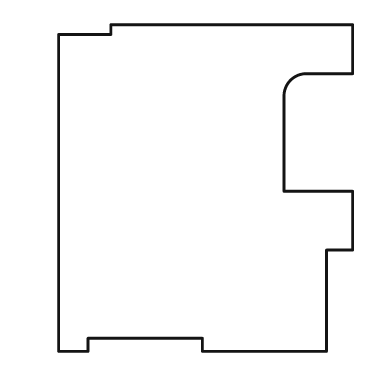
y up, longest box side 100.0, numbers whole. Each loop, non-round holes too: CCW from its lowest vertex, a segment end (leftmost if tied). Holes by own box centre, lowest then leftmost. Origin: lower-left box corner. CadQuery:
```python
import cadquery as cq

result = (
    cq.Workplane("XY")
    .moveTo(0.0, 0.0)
    .lineTo(9.0, 0.0)
    .lineTo(9.0, 4.0)
    .lineTo(44.0, 4.0)
    .lineTo(44.0, 0.0)
    .lineTo(82.0, 0.0)
    .lineTo(82.0, 31.0)
    .lineTo(90.0, 31.0)
    .lineTo(90.0, 49.0)
    .lineTo(69.0, 49.0)
    .lineTo(69.0, 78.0)
    .threePointArc((71.0, 83.0), (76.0, 85.0))
    .lineTo(90.0, 85.0)
    .lineTo(90.0, 100.0)
    .lineTo(16.0, 100.0)
    .lineTo(16.0, 97.0)
    .lineTo(0.0, 97.0)
    .close()
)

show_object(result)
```